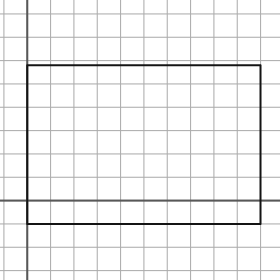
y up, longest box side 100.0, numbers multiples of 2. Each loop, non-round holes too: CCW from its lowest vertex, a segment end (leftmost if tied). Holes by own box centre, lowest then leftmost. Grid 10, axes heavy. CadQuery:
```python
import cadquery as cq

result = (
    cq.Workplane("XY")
    .moveTo(0.0, -10.0)
    .lineTo(100.0, -10.0)
    .lineTo(100.0, 58.0)
    .lineTo(0.0, 58.0)
    .close()
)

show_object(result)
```